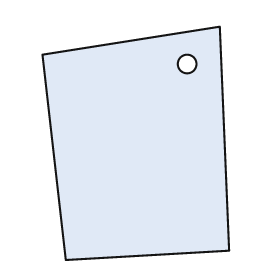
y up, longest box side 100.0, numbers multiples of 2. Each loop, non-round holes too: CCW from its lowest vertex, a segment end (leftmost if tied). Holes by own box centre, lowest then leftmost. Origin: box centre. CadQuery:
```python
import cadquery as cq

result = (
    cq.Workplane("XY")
    .moveTo(-30.0, -50.0)
    .lineTo(40.0, -46.0)
    .lineTo(36.0, 50.0)
    .lineTo(-40.0, 38.0)
    .close()
    .moveTo(22.0, 34.0)
    .circle(4.0)
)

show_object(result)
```